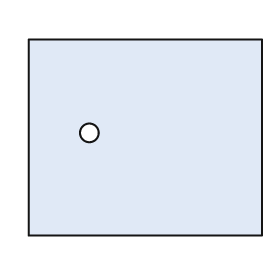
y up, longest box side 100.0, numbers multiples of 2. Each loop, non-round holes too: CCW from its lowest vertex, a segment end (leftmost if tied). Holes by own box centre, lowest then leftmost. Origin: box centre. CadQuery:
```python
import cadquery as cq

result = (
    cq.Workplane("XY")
    .moveTo(-50.0, -42.0)
    .lineTo(50.0, -42.0)
    .lineTo(50.0, 42.0)
    .lineTo(-50.0, 42.0)
    .close()
    .moveTo(-24.0, 2.0)
    .circle(4.0)
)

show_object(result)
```